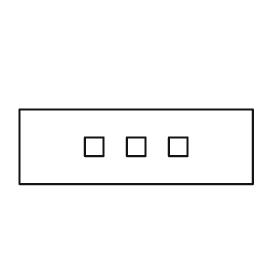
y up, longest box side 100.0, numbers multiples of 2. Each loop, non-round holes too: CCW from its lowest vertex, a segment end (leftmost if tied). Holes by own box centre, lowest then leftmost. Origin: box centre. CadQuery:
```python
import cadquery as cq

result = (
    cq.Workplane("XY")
    .moveTo(-50.0, -16.0)
    .lineTo(50.0, -16.0)
    .lineTo(50.0, 16.0)
    .lineTo(-50.0, 16.0)
    .close()
    .moveTo(-22.0, -4.0)
    .lineTo(-14.0, -4.0)
    .lineTo(-14.0, 4.0)
    .lineTo(-22.0, 4.0)
    .close()
    .moveTo(-4.0, -4.0)
    .lineTo(4.0, -4.0)
    .lineTo(4.0, 4.0)
    .lineTo(-4.0, 4.0)
    .close()
    .moveTo(14.0, -4.0)
    .lineTo(22.0, -4.0)
    .lineTo(22.0, 4.0)
    .lineTo(14.0, 4.0)
    .close()
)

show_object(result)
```